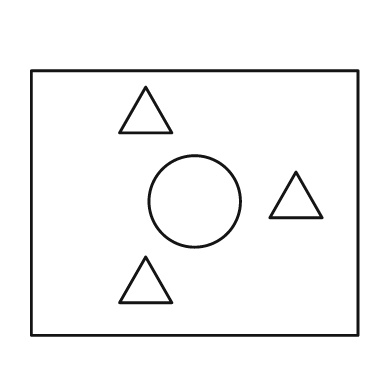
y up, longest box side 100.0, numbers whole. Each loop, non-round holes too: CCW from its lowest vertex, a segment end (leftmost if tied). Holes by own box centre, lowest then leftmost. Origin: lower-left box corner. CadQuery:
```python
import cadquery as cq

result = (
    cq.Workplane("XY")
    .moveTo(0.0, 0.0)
    .lineTo(100.0, 0.0)
    .lineTo(100.0, 81.0)
    .lineTo(0.0, 81.0)
    .close()
    .moveTo(27.0, 10.0)
    .lineTo(43.0, 10.0)
    .lineTo(35.0, 24.0)
    .close()
    .moveTo(50.0, 41.0)
    .circle(14.0)
    .moveTo(73.0, 36.0)
    .lineTo(89.0, 36.0)
    .lineTo(81.0, 50.0)
    .close()
    .moveTo(27.0, 62.0)
    .lineTo(43.0, 62.0)
    .lineTo(35.0, 76.0)
    .close()
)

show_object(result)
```